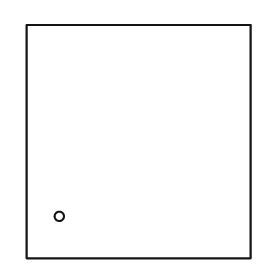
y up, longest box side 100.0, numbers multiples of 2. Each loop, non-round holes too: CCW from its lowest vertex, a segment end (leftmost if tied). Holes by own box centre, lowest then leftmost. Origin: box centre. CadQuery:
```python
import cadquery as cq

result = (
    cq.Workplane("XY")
    .moveTo(-48.0, -50.0)
    .lineTo(48.0, -50.0)
    .lineTo(48.0, 50.0)
    .lineTo(-48.0, 50.0)
    .close()
    .moveTo(-34.0, -32.0)
    .circle(2.0)
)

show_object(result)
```